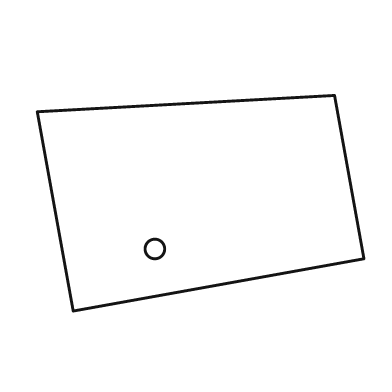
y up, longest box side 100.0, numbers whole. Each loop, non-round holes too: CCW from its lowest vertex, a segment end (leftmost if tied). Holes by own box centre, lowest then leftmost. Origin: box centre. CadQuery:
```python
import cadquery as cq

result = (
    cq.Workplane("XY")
    .moveTo(-39.0, -33.0)
    .lineTo(50.0, -17.0)
    .lineTo(41.0, 33.0)
    .lineTo(-50.0, 28.0)
    .close()
    .moveTo(-14.0, -14.0)
    .circle(3.0)
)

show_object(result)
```